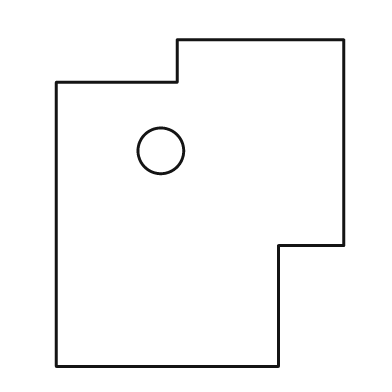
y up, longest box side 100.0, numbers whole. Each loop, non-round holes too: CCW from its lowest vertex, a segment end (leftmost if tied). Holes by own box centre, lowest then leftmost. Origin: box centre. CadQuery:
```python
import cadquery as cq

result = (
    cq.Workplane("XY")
    .moveTo(-44.0, -50.0)
    .lineTo(24.0, -50.0)
    .lineTo(24.0, -13.0)
    .lineTo(44.0, -13.0)
    .lineTo(44.0, 50.0)
    .lineTo(-7.0, 50.0)
    .lineTo(-7.0, 37.0)
    .lineTo(-44.0, 37.0)
    .close()
    .moveTo(-12.0, 16.0)
    .circle(7.0)
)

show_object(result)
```